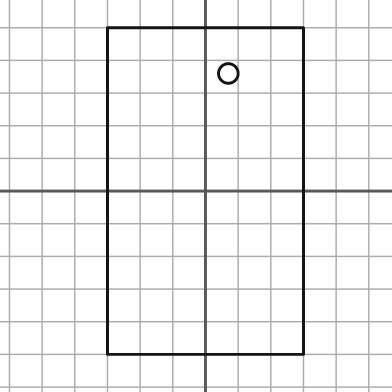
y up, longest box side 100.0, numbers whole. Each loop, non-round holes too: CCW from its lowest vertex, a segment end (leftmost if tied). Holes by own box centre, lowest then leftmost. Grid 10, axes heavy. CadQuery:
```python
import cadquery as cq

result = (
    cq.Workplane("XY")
    .moveTo(-30.0, -50.0)
    .lineTo(30.0, -50.0)
    .lineTo(30.0, 50.0)
    .lineTo(-30.0, 50.0)
    .close()
    .moveTo(7.0, 36.0)
    .circle(3.0)
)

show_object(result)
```